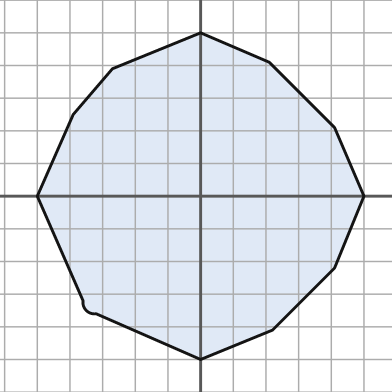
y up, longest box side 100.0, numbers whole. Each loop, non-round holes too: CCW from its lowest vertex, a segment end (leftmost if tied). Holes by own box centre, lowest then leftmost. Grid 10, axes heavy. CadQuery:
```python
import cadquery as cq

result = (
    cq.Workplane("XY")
    .moveTo(0.0, -50.0)
    .lineTo(22.0, -41.0)
    .lineTo(41.0, -22.0)
    .lineTo(50.0, 0.0)
    .lineTo(41.0, 21.0)
    .lineTo(21.0, 41.0)
    .lineTo(0.0, 50.0)
    .lineTo(-27.0, 39.0)
    .lineTo(-39.0, 25.0)
    .lineTo(-50.0, 0.0)
    .lineTo(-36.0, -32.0)
    .threePointArc((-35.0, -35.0), (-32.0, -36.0))
    .close()
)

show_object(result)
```